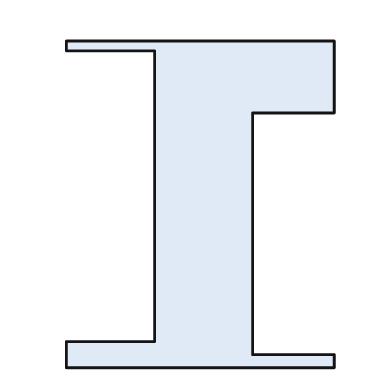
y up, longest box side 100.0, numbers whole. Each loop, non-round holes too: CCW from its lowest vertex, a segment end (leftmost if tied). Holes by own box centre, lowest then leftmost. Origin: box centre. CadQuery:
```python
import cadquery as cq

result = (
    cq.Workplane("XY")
    .moveTo(-41.0, -50.0)
    .lineTo(41.0, -50.0)
    .lineTo(41.0, -46.0)
    .lineTo(16.0, -46.0)
    .lineTo(16.0, 28.0)
    .lineTo(41.0, 28.0)
    .lineTo(41.0, 50.0)
    .lineTo(-41.0, 50.0)
    .lineTo(-41.0, 47.0)
    .lineTo(-14.0, 47.0)
    .lineTo(-14.0, -42.0)
    .lineTo(-41.0, -42.0)
    .close()
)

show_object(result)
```